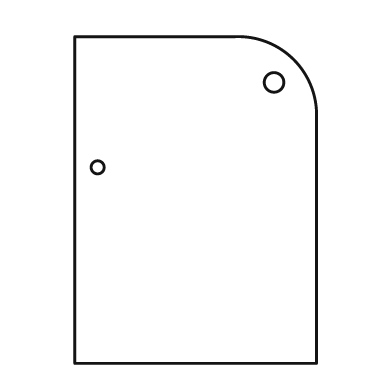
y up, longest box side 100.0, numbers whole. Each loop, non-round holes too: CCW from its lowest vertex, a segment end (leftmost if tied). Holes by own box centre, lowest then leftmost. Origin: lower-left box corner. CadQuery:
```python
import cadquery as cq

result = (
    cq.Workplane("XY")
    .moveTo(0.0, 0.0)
    .lineTo(74.0, 0.0)
    .lineTo(74.0, 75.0)
    .threePointArc((67.0, 93.0), (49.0, 100.0))
    .lineTo(0.0, 100.0)
    .close()
    .moveTo(7.0, 60.0)
    .circle(2.0)
    .moveTo(61.0, 86.0)
    .circle(3.0)
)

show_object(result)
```